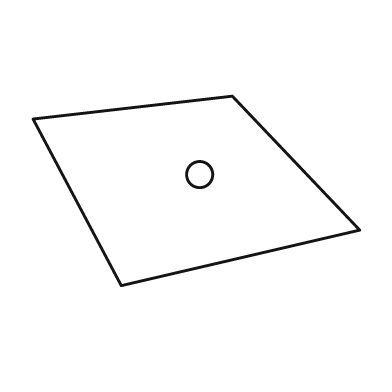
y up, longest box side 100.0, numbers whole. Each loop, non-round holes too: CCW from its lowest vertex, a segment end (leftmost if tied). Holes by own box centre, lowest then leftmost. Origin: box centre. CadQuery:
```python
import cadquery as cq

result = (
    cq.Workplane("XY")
    .moveTo(-23.0, -29.0)
    .lineTo(50.0, -12.0)
    .lineTo(11.0, 29.0)
    .lineTo(-50.0, 22.0)
    .close()
    .moveTo(1.0, 5.0)
    .circle(4.0)
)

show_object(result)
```